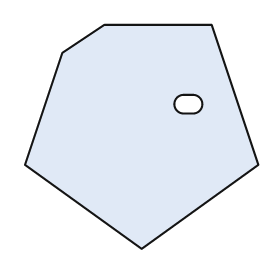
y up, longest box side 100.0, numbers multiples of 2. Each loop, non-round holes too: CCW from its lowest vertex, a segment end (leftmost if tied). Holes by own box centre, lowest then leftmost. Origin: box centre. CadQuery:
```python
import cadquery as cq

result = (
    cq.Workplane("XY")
    .moveTo(0.0, -48.0)
    .lineTo(50.0, -12.0)
    .lineTo(30.0, 48.0)
    .lineTo(-16.0, 48.0)
    .lineTo(-34.0, 36.0)
    .lineTo(-50.0, -12.0)
    .close()
    .moveTo(18.0, 10.0)
    .lineTo(22.0, 10.0)
    .threePointArc((26.0, 14.0), (22.0, 18.0))
    .lineTo(18.0, 18.0)
    .threePointArc((14.0, 14.0), (18.0, 10.0))
    .close()
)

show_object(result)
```